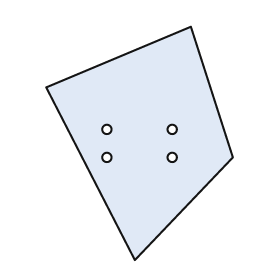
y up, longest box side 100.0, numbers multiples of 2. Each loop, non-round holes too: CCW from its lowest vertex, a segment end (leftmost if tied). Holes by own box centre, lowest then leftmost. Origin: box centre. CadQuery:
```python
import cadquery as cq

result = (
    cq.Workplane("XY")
    .moveTo(-2.0, -50.0)
    .lineTo(40.0, -6.0)
    .lineTo(22.0, 50.0)
    .lineTo(-40.0, 24.0)
    .close()
    .moveTo(-14.0, -6.0)
    .circle(2.0)
    .moveTo(14.0, -6.0)
    .circle(2.0)
    .moveTo(-14.0, 6.0)
    .circle(2.0)
    .moveTo(14.0, 6.0)
    .circle(2.0)
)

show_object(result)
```